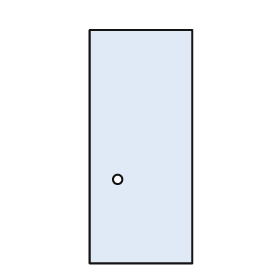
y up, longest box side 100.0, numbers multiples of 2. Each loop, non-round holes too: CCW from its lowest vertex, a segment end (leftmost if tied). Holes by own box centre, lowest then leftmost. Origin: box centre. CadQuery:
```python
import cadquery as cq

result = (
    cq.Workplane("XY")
    .moveTo(-22.0, -50.0)
    .lineTo(22.0, -50.0)
    .lineTo(22.0, 50.0)
    .lineTo(-22.0, 50.0)
    .close()
    .moveTo(-10.0, -14.0)
    .circle(2.0)
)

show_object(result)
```